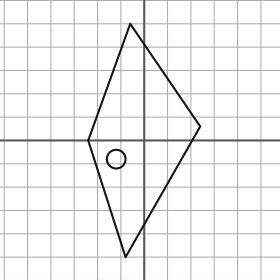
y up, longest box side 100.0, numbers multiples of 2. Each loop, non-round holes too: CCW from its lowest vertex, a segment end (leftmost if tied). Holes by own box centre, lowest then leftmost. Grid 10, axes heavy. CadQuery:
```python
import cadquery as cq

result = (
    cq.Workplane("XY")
    .moveTo(-8.0, -50.0)
    .lineTo(24.0, 6.0)
    .lineTo(-6.0, 50.0)
    .lineTo(-24.0, 0.0)
    .close()
    .moveTo(-12.0, -8.0)
    .circle(4.0)
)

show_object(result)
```